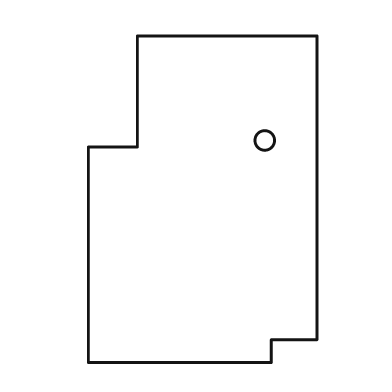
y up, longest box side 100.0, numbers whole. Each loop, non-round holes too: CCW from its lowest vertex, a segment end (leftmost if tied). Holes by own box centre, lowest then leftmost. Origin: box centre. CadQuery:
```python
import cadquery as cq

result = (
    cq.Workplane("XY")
    .moveTo(-35.0, -50.0)
    .lineTo(21.0, -50.0)
    .lineTo(21.0, -43.0)
    .lineTo(35.0, -43.0)
    .lineTo(35.0, 50.0)
    .lineTo(-20.0, 50.0)
    .lineTo(-20.0, 16.0)
    .lineTo(-35.0, 16.0)
    .close()
    .moveTo(19.0, 18.0)
    .circle(3.0)
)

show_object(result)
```